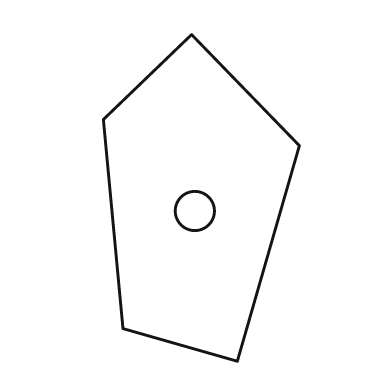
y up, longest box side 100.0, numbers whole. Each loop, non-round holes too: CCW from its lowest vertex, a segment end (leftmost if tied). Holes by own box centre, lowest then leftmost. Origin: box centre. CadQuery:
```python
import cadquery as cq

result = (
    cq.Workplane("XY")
    .moveTo(11.0, -50.0)
    .lineTo(30.0, 16.0)
    .lineTo(-3.0, 50.0)
    .lineTo(-30.0, 24.0)
    .lineTo(-24.0, -40.0)
    .close()
    .moveTo(-2.0, -4.0)
    .circle(6.0)
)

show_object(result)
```